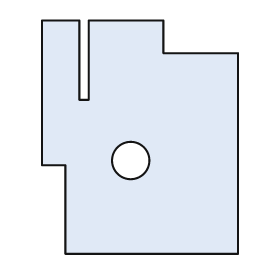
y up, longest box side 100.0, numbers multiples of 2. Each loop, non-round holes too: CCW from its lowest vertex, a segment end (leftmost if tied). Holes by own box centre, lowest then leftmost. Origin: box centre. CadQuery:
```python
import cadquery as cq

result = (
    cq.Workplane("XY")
    .moveTo(-32.0, -50.0)
    .lineTo(42.0, -50.0)
    .lineTo(42.0, 36.0)
    .lineTo(10.0, 36.0)
    .lineTo(10.0, 50.0)
    .lineTo(-22.0, 50.0)
    .lineTo(-22.0, 16.0)
    .lineTo(-26.0, 16.0)
    .lineTo(-26.0, 50.0)
    .lineTo(-42.0, 50.0)
    .lineTo(-42.0, -12.0)
    .lineTo(-32.0, -12.0)
    .close()
    .moveTo(-4.0, -10.0)
    .circle(8.0)
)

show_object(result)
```